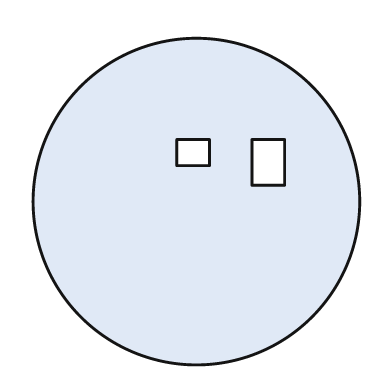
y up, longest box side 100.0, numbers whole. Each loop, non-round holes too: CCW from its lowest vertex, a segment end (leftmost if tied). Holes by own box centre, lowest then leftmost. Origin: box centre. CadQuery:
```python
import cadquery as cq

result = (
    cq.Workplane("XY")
    .moveTo(0.0, 0.0)
    .circle(50.0)
    .moveTo(17.0, 5.0)
    .lineTo(27.0, 5.0)
    .lineTo(27.0, 19.0)
    .lineTo(17.0, 19.0)
    .close()
    .moveTo(-6.0, 11.0)
    .lineTo(4.0, 11.0)
    .lineTo(4.0, 19.0)
    .lineTo(-6.0, 19.0)
    .close()
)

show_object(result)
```